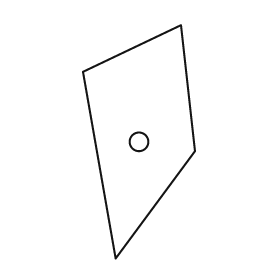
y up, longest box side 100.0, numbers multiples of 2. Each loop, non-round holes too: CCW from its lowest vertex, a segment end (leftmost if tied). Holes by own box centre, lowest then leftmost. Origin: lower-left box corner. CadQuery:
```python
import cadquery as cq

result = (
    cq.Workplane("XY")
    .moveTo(14.0, 0.0)
    .lineTo(48.0, 46.0)
    .lineTo(42.0, 100.0)
    .lineTo(0.0, 80.0)
    .close()
    .moveTo(24.0, 50.0)
    .circle(4.0)
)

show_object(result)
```